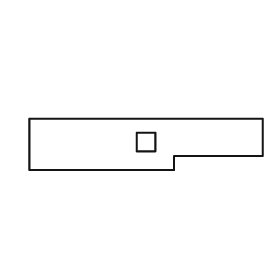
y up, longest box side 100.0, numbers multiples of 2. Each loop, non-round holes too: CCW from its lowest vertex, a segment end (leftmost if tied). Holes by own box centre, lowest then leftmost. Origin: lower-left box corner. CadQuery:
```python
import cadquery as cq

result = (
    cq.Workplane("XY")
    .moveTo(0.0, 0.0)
    .lineTo(62.0, 0.0)
    .lineTo(62.0, 6.0)
    .lineTo(100.0, 6.0)
    .lineTo(100.0, 22.0)
    .lineTo(0.0, 22.0)
    .close()
    .moveTo(46.0, 8.0)
    .lineTo(54.0, 8.0)
    .lineTo(54.0, 16.0)
    .lineTo(46.0, 16.0)
    .close()
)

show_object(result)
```